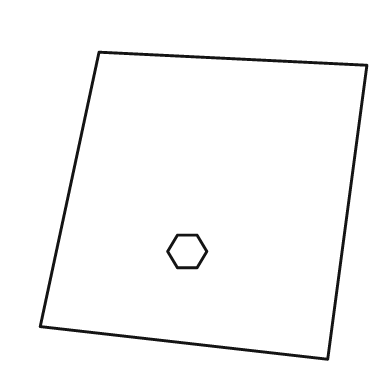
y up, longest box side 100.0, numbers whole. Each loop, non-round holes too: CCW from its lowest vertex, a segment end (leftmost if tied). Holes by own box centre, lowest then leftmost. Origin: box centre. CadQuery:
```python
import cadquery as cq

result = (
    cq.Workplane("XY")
    .moveTo(38.0, -47.0)
    .lineTo(50.0, 43.0)
    .lineTo(-32.0, 47.0)
    .lineTo(-50.0, -37.0)
    .close()
    .moveTo(-8.0, -19.0)
    .lineTo(-2.0, -19.0)
    .lineTo(1.0, -14.0)
    .lineTo(-2.0, -9.0)
    .lineTo(-8.0, -9.0)
    .lineTo(-11.0, -14.0)
    .close()
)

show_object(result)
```